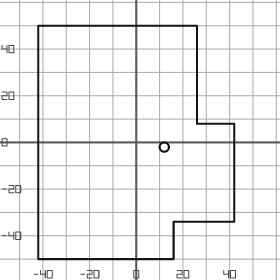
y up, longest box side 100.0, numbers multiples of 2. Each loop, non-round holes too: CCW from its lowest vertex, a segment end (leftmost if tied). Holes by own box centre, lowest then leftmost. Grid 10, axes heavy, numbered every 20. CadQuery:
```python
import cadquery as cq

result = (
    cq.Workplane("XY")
    .moveTo(-42.0, -50.0)
    .lineTo(16.0, -50.0)
    .lineTo(16.0, -34.0)
    .lineTo(42.0, -34.0)
    .lineTo(42.0, 8.0)
    .lineTo(26.0, 8.0)
    .lineTo(26.0, 50.0)
    .lineTo(-42.0, 50.0)
    .close()
    .moveTo(12.0, -2.0)
    .circle(2.0)
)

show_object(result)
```